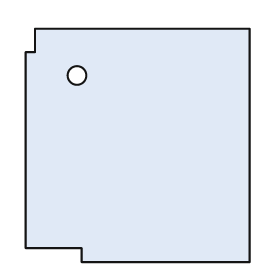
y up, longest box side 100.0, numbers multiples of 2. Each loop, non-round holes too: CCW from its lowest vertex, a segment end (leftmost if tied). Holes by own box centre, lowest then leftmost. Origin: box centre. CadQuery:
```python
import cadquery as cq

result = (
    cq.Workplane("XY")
    .moveTo(-24.0, -50.0)
    .lineTo(48.0, -50.0)
    .lineTo(48.0, 50.0)
    .lineTo(-44.0, 50.0)
    .lineTo(-44.0, 40.0)
    .lineTo(-48.0, 40.0)
    .lineTo(-48.0, -44.0)
    .lineTo(-24.0, -44.0)
    .close()
    .moveTo(-26.0, 30.0)
    .circle(4.0)
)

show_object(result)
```